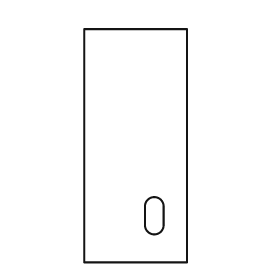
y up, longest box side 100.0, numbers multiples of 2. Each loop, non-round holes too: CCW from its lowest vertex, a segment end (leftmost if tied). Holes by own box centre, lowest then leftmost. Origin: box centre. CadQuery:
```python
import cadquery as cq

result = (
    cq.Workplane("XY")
    .moveTo(-22.0, -50.0)
    .lineTo(22.0, -50.0)
    .lineTo(22.0, 50.0)
    .lineTo(-22.0, 50.0)
    .close()
    .moveTo(4.0, -34.0)
    .threePointArc((8.0, -38.0), (12.0, -34.0))
    .lineTo(12.0, -26.0)
    .threePointArc((8.0, -22.0), (4.0, -26.0))
    .close()
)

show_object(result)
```